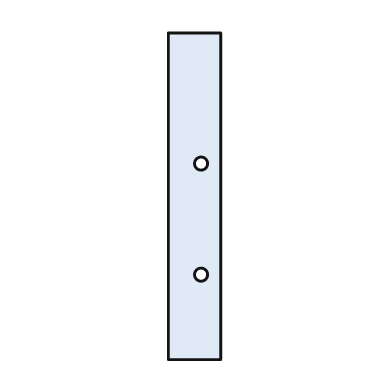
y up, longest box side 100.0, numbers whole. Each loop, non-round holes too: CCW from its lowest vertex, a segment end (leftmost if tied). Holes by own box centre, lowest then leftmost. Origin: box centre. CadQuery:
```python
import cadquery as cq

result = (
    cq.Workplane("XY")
    .moveTo(-8.0, -50.0)
    .lineTo(8.0, -50.0)
    .lineTo(8.0, 50.0)
    .lineTo(-8.0, 50.0)
    .close()
    .moveTo(2.0, -24.0)
    .circle(2.0)
    .moveTo(2.0, 10.0)
    .circle(2.0)
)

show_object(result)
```